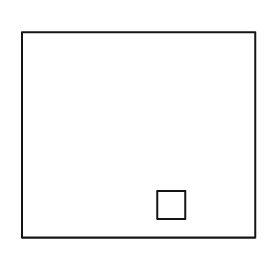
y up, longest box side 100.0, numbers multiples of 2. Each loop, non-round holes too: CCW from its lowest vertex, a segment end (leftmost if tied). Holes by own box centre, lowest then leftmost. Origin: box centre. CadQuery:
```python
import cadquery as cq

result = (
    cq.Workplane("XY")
    .moveTo(-50.0, -44.0)
    .lineTo(50.0, -44.0)
    .lineTo(50.0, 44.0)
    .lineTo(-50.0, 44.0)
    .close()
    .moveTo(8.0, -36.0)
    .lineTo(20.0, -36.0)
    .lineTo(20.0, -24.0)
    .lineTo(8.0, -24.0)
    .close()
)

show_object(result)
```